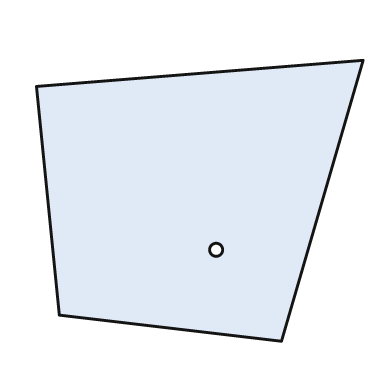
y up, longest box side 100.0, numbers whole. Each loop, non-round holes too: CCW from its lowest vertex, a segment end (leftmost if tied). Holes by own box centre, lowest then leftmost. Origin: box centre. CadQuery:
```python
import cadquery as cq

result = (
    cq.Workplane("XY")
    .moveTo(25.0, -43.0)
    .lineTo(50.0, 43.0)
    .lineTo(-50.0, 35.0)
    .lineTo(-43.0, -35.0)
    .close()
    .moveTo(5.0, -15.0)
    .circle(2.0)
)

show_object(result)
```